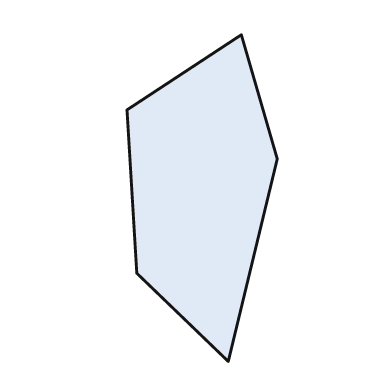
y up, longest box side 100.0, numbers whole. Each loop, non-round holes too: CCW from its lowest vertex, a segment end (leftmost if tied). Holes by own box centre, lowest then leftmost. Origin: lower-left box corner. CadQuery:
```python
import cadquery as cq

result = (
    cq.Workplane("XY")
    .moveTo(31.0, 0.0)
    .lineTo(46.0, 62.0)
    .lineTo(35.0, 100.0)
    .lineTo(0.0, 77.0)
    .lineTo(3.0, 27.0)
    .close()
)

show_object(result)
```